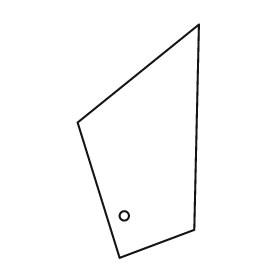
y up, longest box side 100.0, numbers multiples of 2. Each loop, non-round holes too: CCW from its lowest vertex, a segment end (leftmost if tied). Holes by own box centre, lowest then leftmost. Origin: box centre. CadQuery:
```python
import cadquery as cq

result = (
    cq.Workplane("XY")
    .moveTo(-8.0, -50.0)
    .lineTo(24.0, -38.0)
    .lineTo(26.0, 50.0)
    .lineTo(-26.0, 8.0)
    .close()
    .moveTo(-6.0, -32.0)
    .circle(2.0)
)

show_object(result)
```